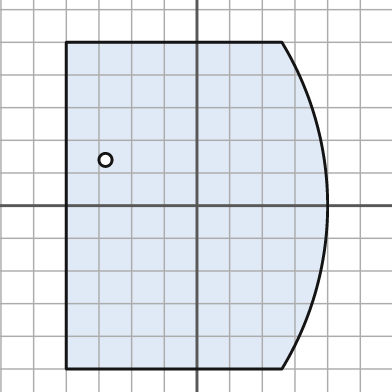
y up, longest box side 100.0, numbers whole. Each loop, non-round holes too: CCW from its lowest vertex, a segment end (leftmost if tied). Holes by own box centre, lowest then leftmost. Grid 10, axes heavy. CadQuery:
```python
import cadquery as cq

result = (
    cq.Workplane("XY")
    .moveTo(-40.0, -50.0)
    .lineTo(26.0, -50.0)
    .threePointArc((40.0, 0.0), (26.0, 50.0))
    .lineTo(-40.0, 50.0)
    .close()
    .moveTo(-28.0, 14.0)
    .circle(2.0)
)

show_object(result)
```